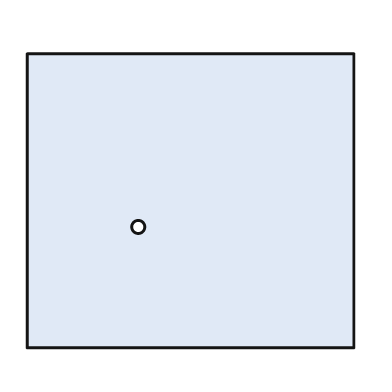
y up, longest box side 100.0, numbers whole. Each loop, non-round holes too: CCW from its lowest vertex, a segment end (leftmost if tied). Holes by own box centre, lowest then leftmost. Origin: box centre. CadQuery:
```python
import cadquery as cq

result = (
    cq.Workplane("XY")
    .moveTo(-50.0, -45.0)
    .lineTo(50.0, -45.0)
    .lineTo(50.0, 45.0)
    .lineTo(-50.0, 45.0)
    .close()
    .moveTo(-16.0, -8.0)
    .circle(2.0)
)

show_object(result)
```